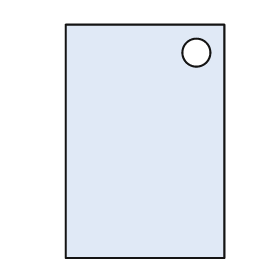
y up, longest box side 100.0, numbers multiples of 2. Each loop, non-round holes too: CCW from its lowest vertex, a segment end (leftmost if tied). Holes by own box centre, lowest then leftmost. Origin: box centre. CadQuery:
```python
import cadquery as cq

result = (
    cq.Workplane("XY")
    .moveTo(-34.0, -50.0)
    .lineTo(34.0, -50.0)
    .lineTo(34.0, 50.0)
    .lineTo(-34.0, 50.0)
    .close()
    .moveTo(22.0, 38.0)
    .circle(6.0)
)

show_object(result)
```